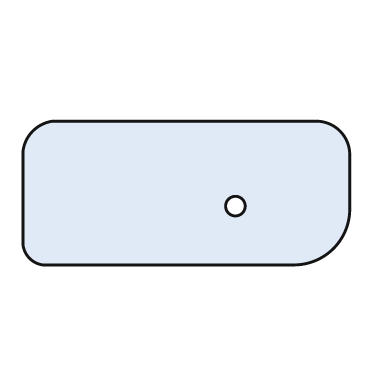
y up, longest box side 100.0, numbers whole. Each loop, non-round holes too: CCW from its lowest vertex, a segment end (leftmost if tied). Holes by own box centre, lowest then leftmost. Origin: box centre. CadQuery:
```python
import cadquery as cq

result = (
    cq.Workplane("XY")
    .moveTo(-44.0, -22.0)
    .lineTo(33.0, -22.0)
    .threePointArc((45.0, -17.0), (50.0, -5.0))
    .lineTo(50.0, 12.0)
    .threePointArc((47.0, 19.0), (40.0, 22.0))
    .lineTo(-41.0, 22.0)
    .threePointArc((-47.0, 19.0), (-50.0, 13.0))
    .lineTo(-50.0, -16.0)
    .threePointArc((-48.0, -20.0), (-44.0, -22.0))
    .close()
    .moveTo(15.0, -4.0)
    .circle(3.0)
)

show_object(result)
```